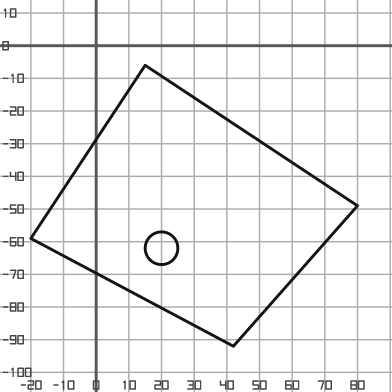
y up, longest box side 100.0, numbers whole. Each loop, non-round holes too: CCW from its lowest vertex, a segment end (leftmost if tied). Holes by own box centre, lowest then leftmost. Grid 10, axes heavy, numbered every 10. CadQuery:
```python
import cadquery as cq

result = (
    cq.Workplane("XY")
    .moveTo(42.0, -92.0)
    .lineTo(80.0, -49.0)
    .lineTo(15.0, -6.0)
    .lineTo(-20.0, -59.0)
    .close()
    .moveTo(20.0, -62.0)
    .circle(5.0)
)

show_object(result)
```